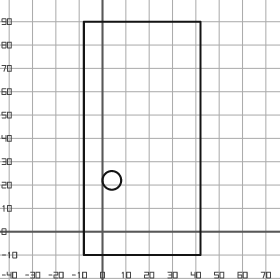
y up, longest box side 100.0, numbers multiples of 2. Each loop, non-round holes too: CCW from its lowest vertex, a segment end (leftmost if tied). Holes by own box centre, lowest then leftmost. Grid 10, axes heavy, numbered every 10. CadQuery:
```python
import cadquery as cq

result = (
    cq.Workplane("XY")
    .moveTo(-8.0, -10.0)
    .lineTo(42.0, -10.0)
    .lineTo(42.0, 90.0)
    .lineTo(-8.0, 90.0)
    .close()
    .moveTo(4.0, 22.0)
    .circle(4.0)
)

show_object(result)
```